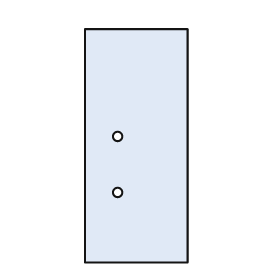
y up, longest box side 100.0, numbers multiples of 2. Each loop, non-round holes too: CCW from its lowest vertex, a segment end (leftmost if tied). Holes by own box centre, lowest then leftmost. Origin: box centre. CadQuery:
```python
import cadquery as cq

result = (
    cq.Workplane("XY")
    .moveTo(-22.0, -50.0)
    .lineTo(22.0, -50.0)
    .lineTo(22.0, 50.0)
    .lineTo(-22.0, 50.0)
    .close()
    .moveTo(-8.0, -20.0)
    .circle(2.0)
    .moveTo(-8.0, 4.0)
    .circle(2.0)
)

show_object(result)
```